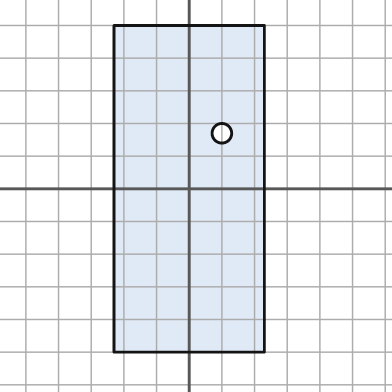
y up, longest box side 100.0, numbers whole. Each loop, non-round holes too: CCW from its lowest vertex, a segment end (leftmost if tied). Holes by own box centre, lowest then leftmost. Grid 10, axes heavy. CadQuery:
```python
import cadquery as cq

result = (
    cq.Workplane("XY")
    .moveTo(-23.0, -50.0)
    .lineTo(23.0, -50.0)
    .lineTo(23.0, 50.0)
    .lineTo(-23.0, 50.0)
    .close()
    .moveTo(10.0, 17.0)
    .circle(3.0)
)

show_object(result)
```